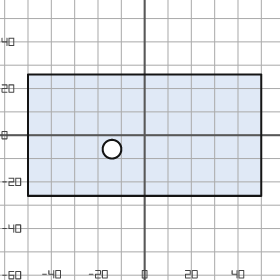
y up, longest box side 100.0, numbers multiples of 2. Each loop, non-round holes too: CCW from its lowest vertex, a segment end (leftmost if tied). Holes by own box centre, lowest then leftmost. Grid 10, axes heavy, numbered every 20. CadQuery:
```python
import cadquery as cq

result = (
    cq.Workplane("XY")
    .moveTo(-50.0, -26.0)
    .lineTo(50.0, -26.0)
    .lineTo(50.0, 26.0)
    .lineTo(-50.0, 26.0)
    .close()
    .moveTo(-14.0, -6.0)
    .circle(4.0)
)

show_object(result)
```